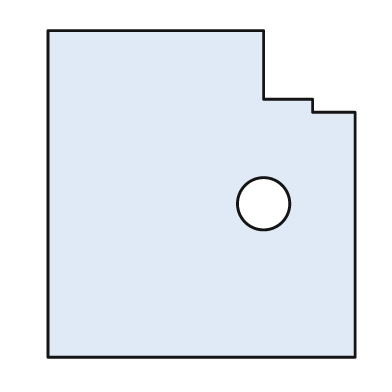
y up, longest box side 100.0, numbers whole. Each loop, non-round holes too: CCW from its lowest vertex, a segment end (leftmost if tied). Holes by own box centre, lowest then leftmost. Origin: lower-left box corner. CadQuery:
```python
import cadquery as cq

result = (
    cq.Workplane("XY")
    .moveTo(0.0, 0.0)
    .lineTo(94.0, 0.0)
    .lineTo(94.0, 75.0)
    .lineTo(81.0, 75.0)
    .lineTo(81.0, 79.0)
    .lineTo(66.0, 79.0)
    .lineTo(66.0, 100.0)
    .lineTo(0.0, 100.0)
    .close()
    .moveTo(66.0, 47.0)
    .circle(8.0)
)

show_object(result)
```